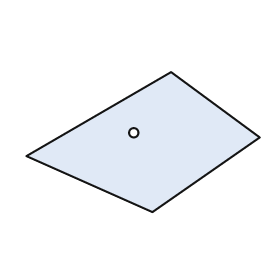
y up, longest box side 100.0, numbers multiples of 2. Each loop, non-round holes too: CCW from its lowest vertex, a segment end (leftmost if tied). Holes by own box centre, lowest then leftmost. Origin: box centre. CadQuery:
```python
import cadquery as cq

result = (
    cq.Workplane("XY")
    .moveTo(4.0, -30.0)
    .lineTo(50.0, 2.0)
    .lineTo(12.0, 30.0)
    .lineTo(-50.0, -6.0)
    .close()
    .moveTo(-4.0, 4.0)
    .circle(2.0)
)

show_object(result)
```